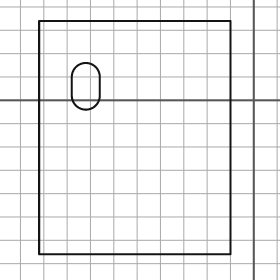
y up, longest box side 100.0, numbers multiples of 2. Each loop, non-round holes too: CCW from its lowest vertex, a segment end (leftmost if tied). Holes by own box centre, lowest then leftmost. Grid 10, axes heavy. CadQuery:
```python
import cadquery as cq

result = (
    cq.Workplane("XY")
    .moveTo(-92.0, -66.0)
    .lineTo(-10.0, -66.0)
    .lineTo(-10.0, 34.0)
    .lineTo(-92.0, 34.0)
    .close()
    .moveTo(-78.0, 2.0)
    .threePointArc((-72.0, -4.0), (-66.0, 2.0))
    .lineTo(-66.0, 10.0)
    .threePointArc((-72.0, 16.0), (-78.0, 10.0))
    .close()
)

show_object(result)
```